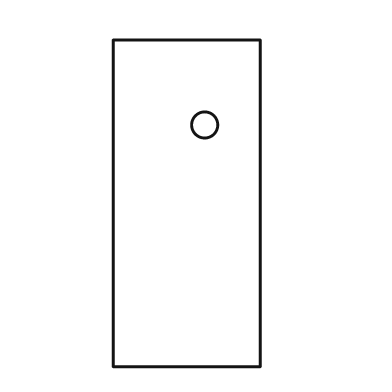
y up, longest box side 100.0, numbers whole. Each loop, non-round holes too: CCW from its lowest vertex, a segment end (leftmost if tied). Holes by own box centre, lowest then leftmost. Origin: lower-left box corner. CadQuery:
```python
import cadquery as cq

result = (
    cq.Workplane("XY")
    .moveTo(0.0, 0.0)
    .lineTo(45.0, 0.0)
    .lineTo(45.0, 100.0)
    .lineTo(0.0, 100.0)
    .close()
    .moveTo(28.0, 74.0)
    .circle(4.0)
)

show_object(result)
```